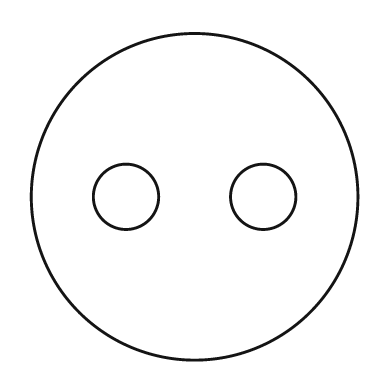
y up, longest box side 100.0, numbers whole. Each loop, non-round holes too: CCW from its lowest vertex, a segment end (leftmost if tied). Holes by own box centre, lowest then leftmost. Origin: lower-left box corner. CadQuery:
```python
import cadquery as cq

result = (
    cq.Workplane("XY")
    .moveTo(50.0, 50.0)
    .circle(50.0)
    .moveTo(29.0, 50.0)
    .circle(10.0)
    .moveTo(71.0, 50.0)
    .circle(10.0)
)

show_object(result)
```